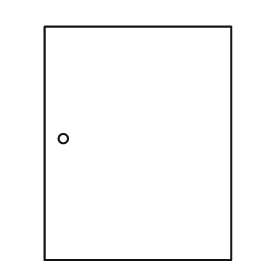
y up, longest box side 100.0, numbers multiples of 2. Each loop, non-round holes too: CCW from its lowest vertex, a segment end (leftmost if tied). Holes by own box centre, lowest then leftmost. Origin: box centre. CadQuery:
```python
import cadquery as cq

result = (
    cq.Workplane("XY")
    .moveTo(-40.0, -50.0)
    .lineTo(40.0, -50.0)
    .lineTo(40.0, 50.0)
    .lineTo(-40.0, 50.0)
    .close()
    .moveTo(-32.0, 2.0)
    .circle(2.0)
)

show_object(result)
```